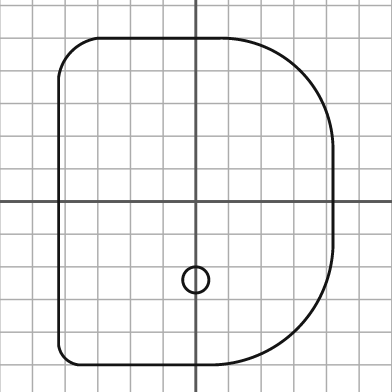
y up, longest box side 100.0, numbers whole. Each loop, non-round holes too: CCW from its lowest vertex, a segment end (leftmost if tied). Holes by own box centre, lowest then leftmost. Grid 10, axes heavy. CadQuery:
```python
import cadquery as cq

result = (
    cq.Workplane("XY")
    .moveTo(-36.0, -50.0)
    .lineTo(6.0, -50.0)
    .threePointArc((31.0, -39.0), (42.0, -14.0))
    .lineTo(42.0, 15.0)
    .threePointArc((32.0, 40.0), (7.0, 50.0))
    .lineTo(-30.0, 50.0)
    .threePointArc((-38.0, 46.0), (-42.0, 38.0))
    .lineTo(-42.0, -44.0)
    .threePointArc((-40.0, -48.0), (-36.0, -50.0))
    .close()
    .moveTo(0.0, -24.0)
    .circle(4.0)
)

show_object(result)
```